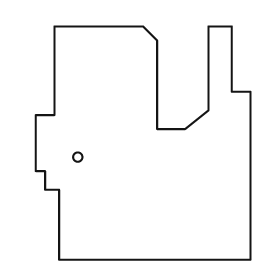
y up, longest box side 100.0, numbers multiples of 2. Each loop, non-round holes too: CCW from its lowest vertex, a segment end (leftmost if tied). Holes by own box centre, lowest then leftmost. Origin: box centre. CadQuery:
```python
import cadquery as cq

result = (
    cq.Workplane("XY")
    .moveTo(-36.0, -50.0)
    .lineTo(46.0, -50.0)
    .lineTo(46.0, 22.0)
    .lineTo(38.0, 22.0)
    .lineTo(38.0, 50.0)
    .lineTo(28.0, 50.0)
    .lineTo(28.0, 14.0)
    .lineTo(18.0, 6.0)
    .lineTo(6.0, 6.0)
    .lineTo(6.0, 44.0)
    .lineTo(0.0, 50.0)
    .lineTo(-38.0, 50.0)
    .lineTo(-38.0, 12.0)
    .lineTo(-46.0, 12.0)
    .lineTo(-46.0, -12.0)
    .lineTo(-42.0, -12.0)
    .lineTo(-42.0, -20.0)
    .lineTo(-36.0, -20.0)
    .close()
    .moveTo(-28.0, -6.0)
    .circle(2.0)
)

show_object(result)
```